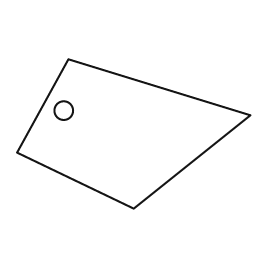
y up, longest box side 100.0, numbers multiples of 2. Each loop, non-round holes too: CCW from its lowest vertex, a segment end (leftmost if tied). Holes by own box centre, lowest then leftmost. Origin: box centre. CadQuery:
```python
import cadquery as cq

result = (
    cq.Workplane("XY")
    .moveTo(0.0, -32.0)
    .lineTo(50.0, 8.0)
    .lineTo(-28.0, 32.0)
    .lineTo(-50.0, -8.0)
    .close()
    .moveTo(-30.0, 10.0)
    .circle(4.0)
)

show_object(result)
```